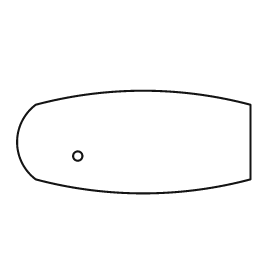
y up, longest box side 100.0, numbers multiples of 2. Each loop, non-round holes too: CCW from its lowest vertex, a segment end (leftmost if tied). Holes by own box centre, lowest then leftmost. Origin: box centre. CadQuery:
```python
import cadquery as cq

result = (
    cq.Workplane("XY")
    .moveTo(-42.0, -16.0)
    .threePointArc((4.0, -22.0), (50.0, -16.0))
    .lineTo(50.0, 16.0)
    .threePointArc((4.0, 22.0), (-42.0, 16.0))
    .threePointArc((-50.0, 0.0), (-42.0, -16.0))
    .close()
    .moveTo(-24.0, -6.0)
    .circle(2.0)
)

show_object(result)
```